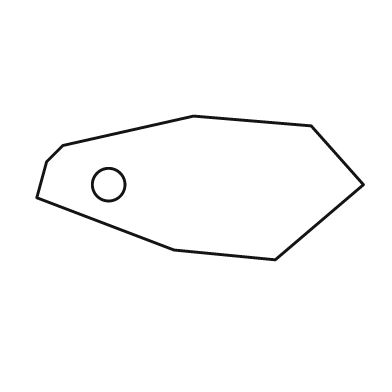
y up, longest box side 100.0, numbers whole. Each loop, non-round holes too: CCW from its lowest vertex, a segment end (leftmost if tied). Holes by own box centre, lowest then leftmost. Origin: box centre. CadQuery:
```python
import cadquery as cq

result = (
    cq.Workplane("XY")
    .moveTo(23.0, -22.0)
    .lineTo(50.0, 1.0)
    .lineTo(34.0, 19.0)
    .lineTo(-2.0, 22.0)
    .lineTo(-42.0, 13.0)
    .lineTo(-47.0, 8.0)
    .lineTo(-50.0, -3.0)
    .lineTo(-8.0, -19.0)
    .close()
    .moveTo(-28.0, 1.0)
    .circle(5.0)
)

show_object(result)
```